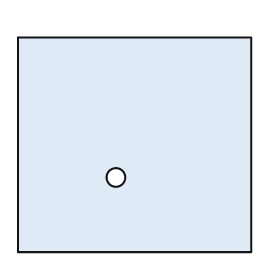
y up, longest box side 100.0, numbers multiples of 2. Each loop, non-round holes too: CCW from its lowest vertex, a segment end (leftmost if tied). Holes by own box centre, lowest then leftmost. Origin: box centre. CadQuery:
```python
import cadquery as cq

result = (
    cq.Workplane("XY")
    .moveTo(-50.0, -46.0)
    .lineTo(50.0, -46.0)
    .lineTo(50.0, 46.0)
    .lineTo(-50.0, 46.0)
    .close()
    .moveTo(-8.0, -14.0)
    .circle(4.0)
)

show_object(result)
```